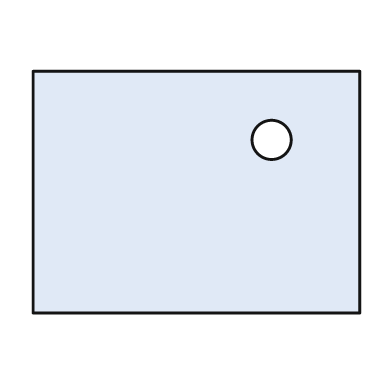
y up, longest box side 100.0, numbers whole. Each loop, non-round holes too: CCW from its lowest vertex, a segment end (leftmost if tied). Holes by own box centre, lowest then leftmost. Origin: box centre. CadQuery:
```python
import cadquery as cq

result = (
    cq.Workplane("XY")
    .moveTo(-50.0, -37.0)
    .lineTo(50.0, -37.0)
    .lineTo(50.0, 37.0)
    .lineTo(-50.0, 37.0)
    .close()
    .moveTo(23.0, 16.0)
    .circle(6.0)
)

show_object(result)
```